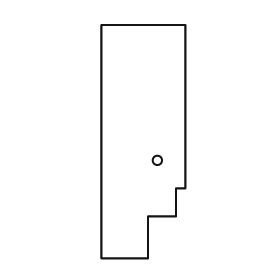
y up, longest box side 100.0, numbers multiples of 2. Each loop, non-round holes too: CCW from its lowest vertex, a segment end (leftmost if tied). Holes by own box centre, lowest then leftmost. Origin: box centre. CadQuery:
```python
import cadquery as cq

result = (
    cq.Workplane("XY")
    .moveTo(-18.0, -50.0)
    .lineTo(2.0, -50.0)
    .lineTo(2.0, -32.0)
    .lineTo(14.0, -32.0)
    .lineTo(14.0, -20.0)
    .lineTo(18.0, -20.0)
    .lineTo(18.0, 50.0)
    .lineTo(-18.0, 50.0)
    .close()
    .moveTo(6.0, -8.0)
    .circle(2.0)
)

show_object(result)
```